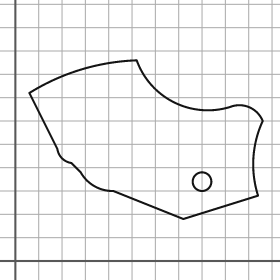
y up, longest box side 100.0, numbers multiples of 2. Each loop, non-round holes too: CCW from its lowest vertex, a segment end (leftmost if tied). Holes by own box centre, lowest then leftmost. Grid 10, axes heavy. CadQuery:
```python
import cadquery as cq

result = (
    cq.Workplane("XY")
    .moveTo(72.0, 18.0)
    .lineTo(104.0, 28.0)
    .threePointArc((102.0, 44.0), (106.0, 60.0))
    .threePointArc((100.0, 66.0), (92.0, 66.0))
    .threePointArc((68.0, 68.0), (52.0, 86.0))
    .threePointArc((28.0, 82.0), (6.0, 72.0))
    .lineTo(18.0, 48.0)
    .threePointArc((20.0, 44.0), (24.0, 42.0))
    .lineTo(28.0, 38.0)
    .threePointArc((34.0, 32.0), (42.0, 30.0))
    .close()
    .moveTo(80.0, 34.0)
    .circle(4.0)
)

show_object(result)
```